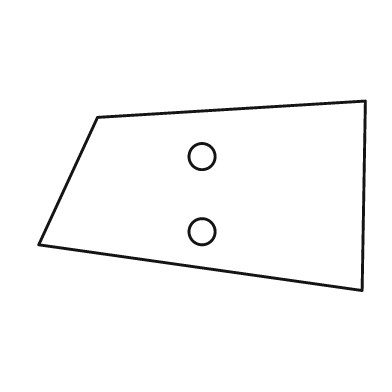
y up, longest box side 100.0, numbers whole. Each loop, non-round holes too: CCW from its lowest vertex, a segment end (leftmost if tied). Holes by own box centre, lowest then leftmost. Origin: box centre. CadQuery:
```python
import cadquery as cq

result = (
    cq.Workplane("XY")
    .moveTo(49.0, -29.0)
    .lineTo(50.0, 29.0)
    .lineTo(-32.0, 24.0)
    .lineTo(-50.0, -15.0)
    .close()
    .moveTo(0.0, -11.0)
    .circle(4.0)
    .moveTo(0.0, 12.0)
    .circle(4.0)
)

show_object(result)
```